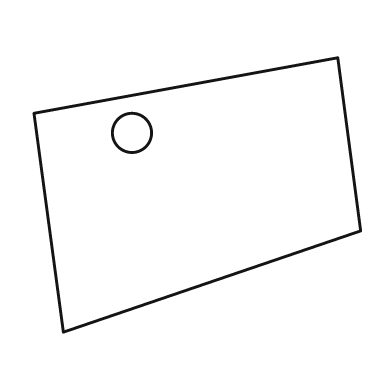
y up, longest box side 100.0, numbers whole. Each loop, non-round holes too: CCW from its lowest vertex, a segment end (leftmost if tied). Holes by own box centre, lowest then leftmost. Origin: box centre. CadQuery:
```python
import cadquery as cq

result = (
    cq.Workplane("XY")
    .moveTo(-41.0, -42.0)
    .lineTo(50.0, -11.0)
    .lineTo(43.0, 42.0)
    .lineTo(-50.0, 25.0)
    .close()
    .moveTo(-20.0, 19.0)
    .circle(6.0)
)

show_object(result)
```